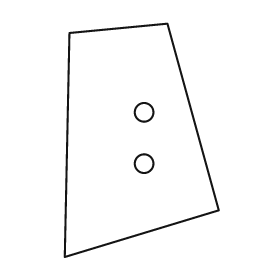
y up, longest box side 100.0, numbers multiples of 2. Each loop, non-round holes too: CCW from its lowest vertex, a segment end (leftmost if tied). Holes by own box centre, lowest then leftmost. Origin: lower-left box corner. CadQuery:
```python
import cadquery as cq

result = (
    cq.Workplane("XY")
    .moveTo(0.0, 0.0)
    .lineTo(66.0, 20.0)
    .lineTo(44.0, 100.0)
    .lineTo(2.0, 96.0)
    .close()
    .moveTo(34.0, 40.0)
    .circle(4.0)
    .moveTo(34.0, 62.0)
    .circle(4.0)
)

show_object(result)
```